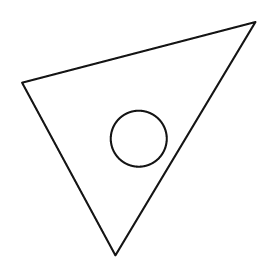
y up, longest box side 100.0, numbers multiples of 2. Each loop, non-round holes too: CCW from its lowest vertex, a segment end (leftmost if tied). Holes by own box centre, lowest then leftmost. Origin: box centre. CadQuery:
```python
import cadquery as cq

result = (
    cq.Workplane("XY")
    .moveTo(-10.0, -50.0)
    .lineTo(50.0, 50.0)
    .lineTo(-50.0, 24.0)
    .close()
    .moveTo(0.0, 0.0)
    .circle(12.0)
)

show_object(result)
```